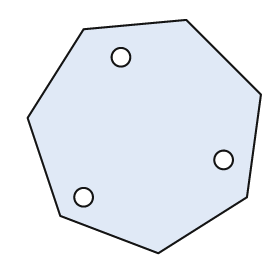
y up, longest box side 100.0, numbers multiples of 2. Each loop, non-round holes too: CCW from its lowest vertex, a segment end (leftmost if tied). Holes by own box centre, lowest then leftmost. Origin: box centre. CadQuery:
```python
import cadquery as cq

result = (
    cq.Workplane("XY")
    .moveTo(6.0, -50.0)
    .lineTo(44.0, -26.0)
    .lineTo(50.0, 18.0)
    .lineTo(18.0, 50.0)
    .lineTo(-26.0, 46.0)
    .lineTo(-50.0, 8.0)
    .lineTo(-36.0, -34.0)
    .close()
    .moveTo(-26.0, -26.0)
    .circle(4.0)
    .moveTo(34.0, -10.0)
    .circle(4.0)
    .moveTo(-10.0, 34.0)
    .circle(4.0)
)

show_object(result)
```